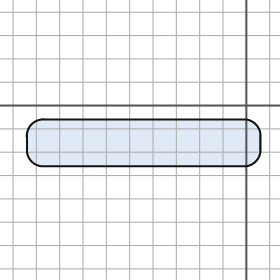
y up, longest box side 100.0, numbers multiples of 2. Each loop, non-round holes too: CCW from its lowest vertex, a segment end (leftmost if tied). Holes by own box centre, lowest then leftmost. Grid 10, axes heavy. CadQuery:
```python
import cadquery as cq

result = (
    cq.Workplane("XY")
    .moveTo(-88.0, -26.0)
    .lineTo(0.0, -26.0)
    .threePointArc((4.0, -24.0), (6.0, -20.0))
    .lineTo(6.0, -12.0)
    .threePointArc((4.0, -8.0), (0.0, -6.0))
    .lineTo(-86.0, -6.0)
    .threePointArc((-92.0, -8.0), (-94.0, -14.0))
    .lineTo(-94.0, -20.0)
    .threePointArc((-92.0, -24.0), (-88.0, -26.0))
    .close()
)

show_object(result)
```